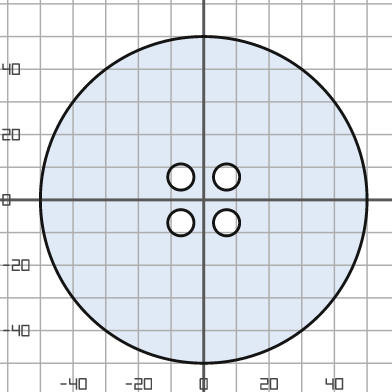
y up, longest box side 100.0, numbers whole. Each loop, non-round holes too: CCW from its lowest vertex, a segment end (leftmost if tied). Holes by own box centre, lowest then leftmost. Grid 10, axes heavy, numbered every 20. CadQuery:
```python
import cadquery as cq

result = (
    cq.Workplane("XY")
    .moveTo(0.0, 0.0)
    .circle(50.0)
    .moveTo(-7.0, -7.0)
    .circle(4.0)
    .moveTo(7.0, -7.0)
    .circle(4.0)
    .moveTo(-7.0, 7.0)
    .circle(4.0)
    .moveTo(7.0, 7.0)
    .circle(4.0)
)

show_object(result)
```